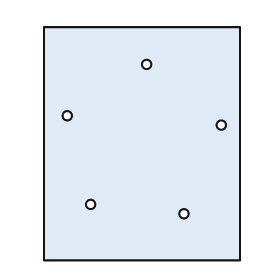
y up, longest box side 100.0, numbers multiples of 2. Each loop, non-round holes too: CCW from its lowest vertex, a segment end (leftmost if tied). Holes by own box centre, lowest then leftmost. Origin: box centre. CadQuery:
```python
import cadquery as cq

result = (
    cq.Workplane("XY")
    .moveTo(-42.0, -50.0)
    .lineTo(42.0, -50.0)
    .lineTo(42.0, 50.0)
    .lineTo(-42.0, 50.0)
    .close()
    .moveTo(18.0, -30.0)
    .circle(2.0)
    .moveTo(-22.0, -26.0)
    .circle(2.0)
    .moveTo(34.0, 8.0)
    .circle(2.0)
    .moveTo(-32.0, 12.0)
    .circle(2.0)
    .moveTo(2.0, 34.0)
    .circle(2.0)
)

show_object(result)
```